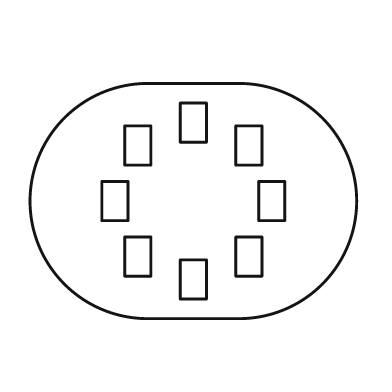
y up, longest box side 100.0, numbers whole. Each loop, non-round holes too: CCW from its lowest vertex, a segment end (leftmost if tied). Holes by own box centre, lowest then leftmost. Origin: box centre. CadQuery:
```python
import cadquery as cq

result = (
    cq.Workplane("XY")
    .moveTo(-14.0, -36.0)
    .lineTo(14.0, -36.0)
    .threePointArc((50.0, 0.0), (14.0, 36.0))
    .lineTo(-14.0, 36.0)
    .threePointArc((-50.0, 0.0), (-14.0, -36.0))
    .close()
    .moveTo(-4.0, -30.0)
    .lineTo(4.0, -30.0)
    .lineTo(4.0, -18.0)
    .lineTo(-4.0, -18.0)
    .close()
    .moveTo(-21.0, -23.0)
    .lineTo(-13.0, -23.0)
    .lineTo(-13.0, -11.0)
    .lineTo(-21.0, -11.0)
    .close()
    .moveTo(13.0, -23.0)
    .lineTo(21.0, -23.0)
    .lineTo(21.0, -11.0)
    .lineTo(13.0, -11.0)
    .close()
    .moveTo(-28.0, -6.0)
    .lineTo(-20.0, -6.0)
    .lineTo(-20.0, 6.0)
    .lineTo(-28.0, 6.0)
    .close()
    .moveTo(20.0, -6.0)
    .lineTo(28.0, -6.0)
    .lineTo(28.0, 6.0)
    .lineTo(20.0, 6.0)
    .close()
    .moveTo(-21.0, 11.0)
    .lineTo(-13.0, 11.0)
    .lineTo(-13.0, 23.0)
    .lineTo(-21.0, 23.0)
    .close()
    .moveTo(13.0, 11.0)
    .lineTo(21.0, 11.0)
    .lineTo(21.0, 23.0)
    .lineTo(13.0, 23.0)
    .close()
    .moveTo(-4.0, 18.0)
    .lineTo(4.0, 18.0)
    .lineTo(4.0, 30.0)
    .lineTo(-4.0, 30.0)
    .close()
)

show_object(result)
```